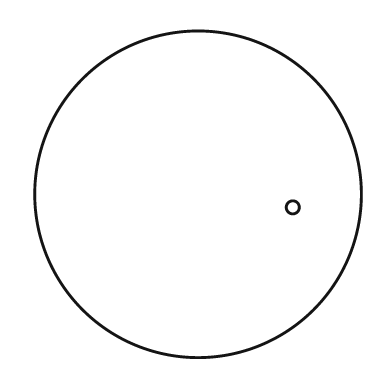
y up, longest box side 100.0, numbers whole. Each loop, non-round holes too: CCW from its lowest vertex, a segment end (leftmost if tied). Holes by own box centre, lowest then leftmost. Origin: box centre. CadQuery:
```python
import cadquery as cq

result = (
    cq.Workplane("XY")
    .moveTo(0.0, 0.0)
    .circle(50.0)
    .moveTo(29.0, -4.0)
    .circle(2.0)
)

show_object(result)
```